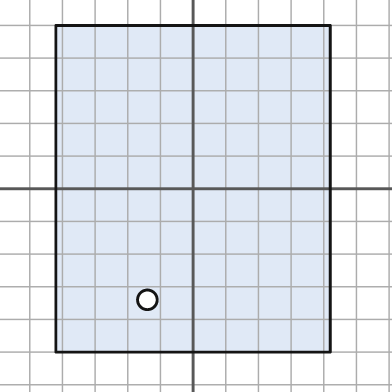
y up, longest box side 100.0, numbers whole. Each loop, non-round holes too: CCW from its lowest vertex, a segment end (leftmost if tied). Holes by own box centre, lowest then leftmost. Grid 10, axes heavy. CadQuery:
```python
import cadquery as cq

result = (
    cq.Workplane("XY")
    .moveTo(-42.0, -50.0)
    .lineTo(42.0, -50.0)
    .lineTo(42.0, 50.0)
    .lineTo(-42.0, 50.0)
    .close()
    .moveTo(-14.0, -34.0)
    .circle(3.0)
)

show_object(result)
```